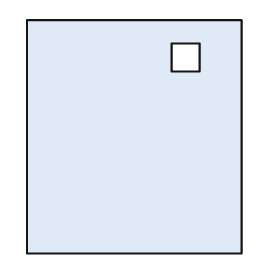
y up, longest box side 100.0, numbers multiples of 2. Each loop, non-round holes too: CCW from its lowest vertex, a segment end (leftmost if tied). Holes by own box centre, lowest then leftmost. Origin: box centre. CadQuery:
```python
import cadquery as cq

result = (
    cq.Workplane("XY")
    .moveTo(-46.0, -50.0)
    .lineTo(46.0, -50.0)
    .lineTo(46.0, 50.0)
    .lineTo(-46.0, 50.0)
    .close()
    .moveTo(16.0, 28.0)
    .lineTo(28.0, 28.0)
    .lineTo(28.0, 40.0)
    .lineTo(16.0, 40.0)
    .close()
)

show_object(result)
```